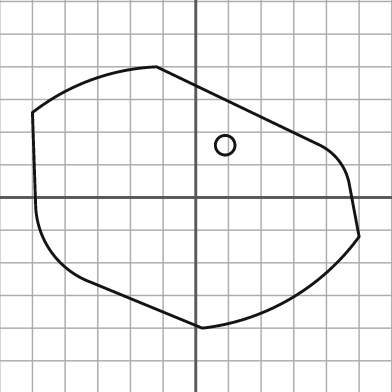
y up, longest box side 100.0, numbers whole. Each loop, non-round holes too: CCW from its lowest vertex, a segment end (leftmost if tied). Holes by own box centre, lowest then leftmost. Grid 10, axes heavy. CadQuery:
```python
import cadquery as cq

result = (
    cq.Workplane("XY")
    .moveTo(2.0, -40.0)
    .threePointArc((29.0, -31.0), (50.0, -12.0))
    .lineTo(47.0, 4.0)
    .threePointArc((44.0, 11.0), (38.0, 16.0))
    .lineTo(-12.0, 40.0)
    .threePointArc((-32.0, 36.0), (-50.0, 26.0))
    .lineTo(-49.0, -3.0)
    .threePointArc((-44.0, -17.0), (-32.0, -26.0))
    .close()
    .moveTo(9.0, 16.0)
    .circle(3.0)
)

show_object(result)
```